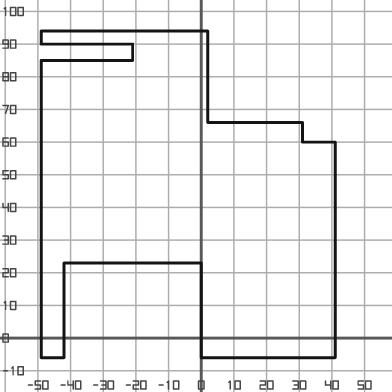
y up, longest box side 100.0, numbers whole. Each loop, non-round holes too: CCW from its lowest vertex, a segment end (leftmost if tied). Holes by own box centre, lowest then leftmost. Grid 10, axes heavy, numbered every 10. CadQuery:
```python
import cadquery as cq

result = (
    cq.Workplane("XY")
    .moveTo(-49.0, -6.0)
    .lineTo(-42.0, -6.0)
    .lineTo(-42.0, 23.0)
    .lineTo(0.0, 23.0)
    .lineTo(0.0, -6.0)
    .lineTo(41.0, -6.0)
    .lineTo(41.0, 60.0)
    .lineTo(31.0, 60.0)
    .lineTo(31.0, 66.0)
    .lineTo(2.0, 66.0)
    .lineTo(2.0, 94.0)
    .lineTo(-49.0, 94.0)
    .lineTo(-49.0, 90.0)
    .lineTo(-21.0, 90.0)
    .lineTo(-21.0, 85.0)
    .lineTo(-49.0, 85.0)
    .close()
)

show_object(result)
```